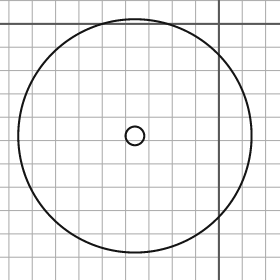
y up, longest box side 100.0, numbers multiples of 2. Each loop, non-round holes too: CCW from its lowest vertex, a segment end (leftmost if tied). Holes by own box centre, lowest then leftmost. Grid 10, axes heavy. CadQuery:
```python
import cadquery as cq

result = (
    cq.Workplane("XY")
    .moveTo(-36.0, -48.0)
    .circle(50.0)
    .moveTo(-36.0, -48.0)
    .circle(4.0)
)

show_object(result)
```